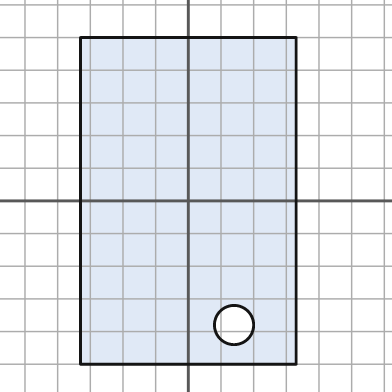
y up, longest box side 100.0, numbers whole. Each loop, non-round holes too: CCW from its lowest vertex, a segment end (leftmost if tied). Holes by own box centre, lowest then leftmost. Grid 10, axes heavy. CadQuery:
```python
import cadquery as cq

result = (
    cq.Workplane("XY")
    .moveTo(-33.0, -50.0)
    .lineTo(33.0, -50.0)
    .lineTo(33.0, 50.0)
    .lineTo(-33.0, 50.0)
    .close()
    .moveTo(14.0, -38.0)
    .circle(6.0)
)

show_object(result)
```